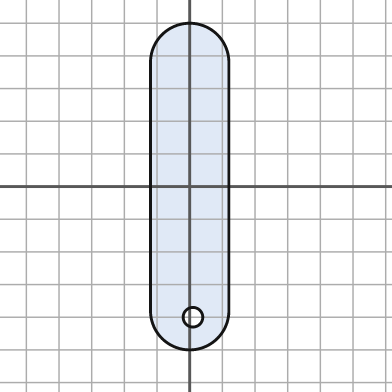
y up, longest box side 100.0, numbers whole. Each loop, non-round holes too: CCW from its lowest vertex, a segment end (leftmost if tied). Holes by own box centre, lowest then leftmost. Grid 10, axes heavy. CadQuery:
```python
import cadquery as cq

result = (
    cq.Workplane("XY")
    .moveTo(-12.0, -38.0)
    .threePointArc((0.0, -50.0), (12.0, -38.0))
    .lineTo(12.0, 38.0)
    .threePointArc((0.0, 50.0), (-12.0, 38.0))
    .close()
    .moveTo(1.0, -40.0)
    .circle(3.0)
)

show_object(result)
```